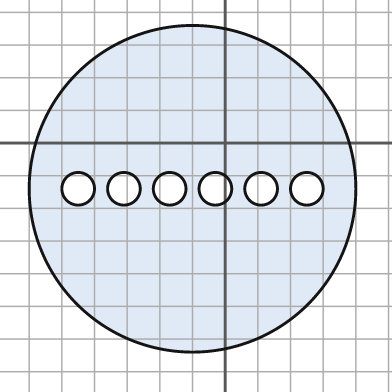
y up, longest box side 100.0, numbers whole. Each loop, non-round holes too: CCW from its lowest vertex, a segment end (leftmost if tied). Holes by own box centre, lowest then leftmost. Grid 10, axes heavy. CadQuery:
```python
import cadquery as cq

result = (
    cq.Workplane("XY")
    .moveTo(-10.0, -14.0)
    .circle(50.0)
    .moveTo(-45.0, -14.0)
    .circle(5.0)
    .moveTo(-31.0, -14.0)
    .circle(5.0)
    .moveTo(-17.0, -14.0)
    .circle(5.0)
    .moveTo(-3.0, -14.0)
    .circle(5.0)
    .moveTo(11.0, -14.0)
    .circle(5.0)
    .moveTo(25.0, -14.0)
    .circle(5.0)
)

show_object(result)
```